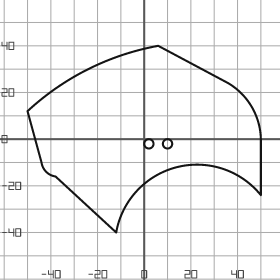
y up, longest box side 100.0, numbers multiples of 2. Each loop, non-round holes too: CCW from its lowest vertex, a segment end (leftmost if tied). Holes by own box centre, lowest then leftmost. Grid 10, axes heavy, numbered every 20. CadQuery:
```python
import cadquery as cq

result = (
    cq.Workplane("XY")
    .moveTo(-12.0, -40.0)
    .threePointArc((14.0, -12.0), (50.0, -24.0))
    .lineTo(50.0, 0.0)
    .threePointArc((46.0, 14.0), (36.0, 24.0))
    .lineTo(6.0, 40.0)
    .threePointArc((-24.0, 30.0), (-50.0, 12.0))
    .lineTo(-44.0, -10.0)
    .threePointArc((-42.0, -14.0), (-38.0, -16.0))
    .close()
    .moveTo(2.0, -2.0)
    .circle(2.0)
    .moveTo(10.0, -2.0)
    .circle(2.0)
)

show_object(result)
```